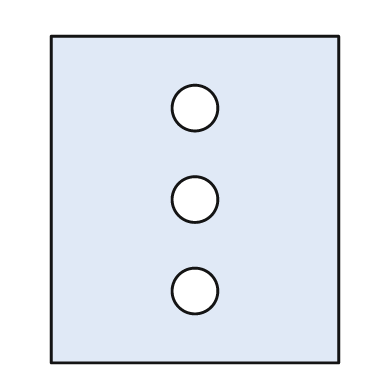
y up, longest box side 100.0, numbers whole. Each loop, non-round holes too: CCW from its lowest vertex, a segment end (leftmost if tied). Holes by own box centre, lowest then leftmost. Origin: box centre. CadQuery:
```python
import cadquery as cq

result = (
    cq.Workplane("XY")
    .moveTo(-44.0, -50.0)
    .lineTo(44.0, -50.0)
    .lineTo(44.0, 50.0)
    .lineTo(-44.0, 50.0)
    .close()
    .moveTo(0.0, -28.0)
    .circle(7.0)
    .moveTo(0.0, 0.0)
    .circle(7.0)
    .moveTo(0.0, 28.0)
    .circle(7.0)
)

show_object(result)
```